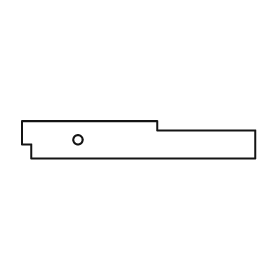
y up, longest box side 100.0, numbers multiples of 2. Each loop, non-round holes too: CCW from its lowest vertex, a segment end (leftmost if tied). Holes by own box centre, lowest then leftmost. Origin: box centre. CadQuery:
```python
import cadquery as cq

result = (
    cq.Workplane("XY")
    .moveTo(-46.0, -8.0)
    .lineTo(50.0, -8.0)
    .lineTo(50.0, 4.0)
    .lineTo(8.0, 4.0)
    .lineTo(8.0, 8.0)
    .lineTo(-50.0, 8.0)
    .lineTo(-50.0, -2.0)
    .lineTo(-46.0, -2.0)
    .close()
    .moveTo(-26.0, 0.0)
    .circle(2.0)
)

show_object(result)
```